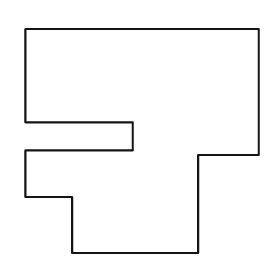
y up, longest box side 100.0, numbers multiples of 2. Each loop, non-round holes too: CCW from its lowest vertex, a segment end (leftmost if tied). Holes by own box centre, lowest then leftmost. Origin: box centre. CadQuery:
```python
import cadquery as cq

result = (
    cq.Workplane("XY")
    .moveTo(-30.0, -48.0)
    .lineTo(24.0, -48.0)
    .lineTo(24.0, -6.0)
    .lineTo(50.0, -6.0)
    .lineTo(50.0, 48.0)
    .lineTo(-50.0, 48.0)
    .lineTo(-50.0, 8.0)
    .lineTo(-4.0, 8.0)
    .lineTo(-4.0, -4.0)
    .lineTo(-50.0, -4.0)
    .lineTo(-50.0, -24.0)
    .lineTo(-30.0, -24.0)
    .close()
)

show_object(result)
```